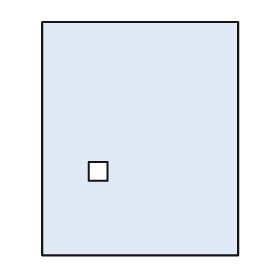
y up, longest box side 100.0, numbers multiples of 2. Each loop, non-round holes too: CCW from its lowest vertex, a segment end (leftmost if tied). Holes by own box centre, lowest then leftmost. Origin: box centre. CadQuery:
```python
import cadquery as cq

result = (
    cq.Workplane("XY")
    .moveTo(-42.0, -50.0)
    .lineTo(42.0, -50.0)
    .lineTo(42.0, 50.0)
    .lineTo(-42.0, 50.0)
    .close()
    .moveTo(-22.0, -18.0)
    .lineTo(-14.0, -18.0)
    .lineTo(-14.0, -10.0)
    .lineTo(-22.0, -10.0)
    .close()
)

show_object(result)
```